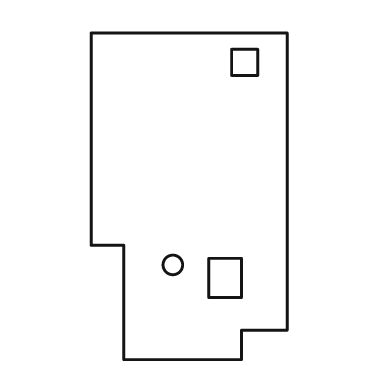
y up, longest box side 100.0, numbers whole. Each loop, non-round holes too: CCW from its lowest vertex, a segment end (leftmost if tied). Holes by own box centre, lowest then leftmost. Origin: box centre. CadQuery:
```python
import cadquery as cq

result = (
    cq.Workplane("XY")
    .moveTo(-20.0, -50.0)
    .lineTo(16.0, -50.0)
    .lineTo(16.0, -41.0)
    .lineTo(30.0, -41.0)
    .lineTo(30.0, 50.0)
    .lineTo(-30.0, 50.0)
    .lineTo(-30.0, -15.0)
    .lineTo(-20.0, -15.0)
    .close()
    .moveTo(6.0, -31.0)
    .lineTo(16.0, -31.0)
    .lineTo(16.0, -19.0)
    .lineTo(6.0, -19.0)
    .close()
    .moveTo(-5.0, -21.0)
    .circle(3.0)
    .moveTo(13.0, 37.0)
    .lineTo(21.0, 37.0)
    .lineTo(21.0, 45.0)
    .lineTo(13.0, 45.0)
    .close()
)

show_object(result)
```